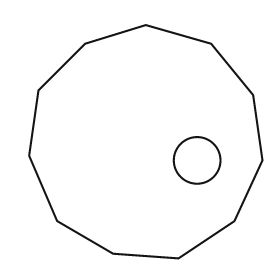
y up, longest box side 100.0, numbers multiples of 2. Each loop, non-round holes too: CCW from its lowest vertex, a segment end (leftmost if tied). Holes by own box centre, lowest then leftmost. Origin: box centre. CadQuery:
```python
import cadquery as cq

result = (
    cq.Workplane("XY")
    .moveTo(14.0, -50.0)
    .lineTo(38.0, -34.0)
    .lineTo(50.0, -8.0)
    .lineTo(46.0, 20.0)
    .lineTo(28.0, 42.0)
    .lineTo(0.0, 50.0)
    .lineTo(-26.0, 42.0)
    .lineTo(-46.0, 22.0)
    .lineTo(-50.0, -6.0)
    .lineTo(-38.0, -34.0)
    .lineTo(-14.0, -48.0)
    .close()
    .moveTo(22.0, -8.0)
    .circle(10.0)
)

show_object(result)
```